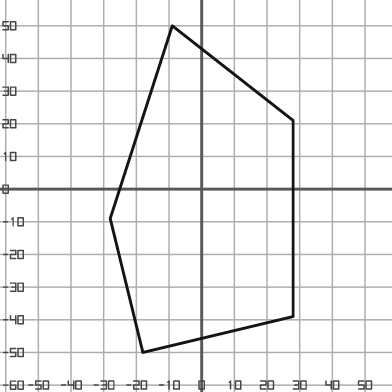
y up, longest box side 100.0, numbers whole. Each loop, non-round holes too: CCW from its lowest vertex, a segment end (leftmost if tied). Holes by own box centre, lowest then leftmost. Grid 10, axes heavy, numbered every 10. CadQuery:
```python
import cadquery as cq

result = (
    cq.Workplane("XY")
    .moveTo(-18.0, -50.0)
    .lineTo(28.0, -39.0)
    .lineTo(28.0, 21.0)
    .lineTo(-9.0, 50.0)
    .lineTo(-28.0, -9.0)
    .close()
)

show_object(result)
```